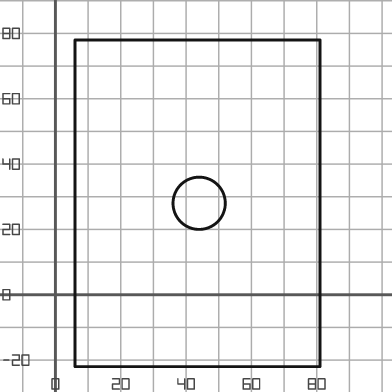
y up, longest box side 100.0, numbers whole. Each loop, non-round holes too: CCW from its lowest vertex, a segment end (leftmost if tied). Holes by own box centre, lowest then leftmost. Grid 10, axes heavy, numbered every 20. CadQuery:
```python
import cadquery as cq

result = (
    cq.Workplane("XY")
    .moveTo(6.0, -22.0)
    .lineTo(81.0, -22.0)
    .lineTo(81.0, 78.0)
    .lineTo(6.0, 78.0)
    .close()
    .moveTo(44.0, 28.0)
    .circle(8.0)
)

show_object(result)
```